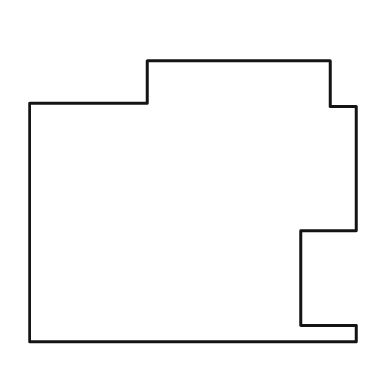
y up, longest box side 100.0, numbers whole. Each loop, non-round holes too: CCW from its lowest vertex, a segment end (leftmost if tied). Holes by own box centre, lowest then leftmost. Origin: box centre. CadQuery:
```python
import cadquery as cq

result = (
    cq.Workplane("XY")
    .moveTo(-50.0, -43.0)
    .lineTo(50.0, -43.0)
    .lineTo(50.0, -38.0)
    .lineTo(33.0, -38.0)
    .lineTo(33.0, -9.0)
    .lineTo(50.0, -9.0)
    .lineTo(50.0, 29.0)
    .lineTo(42.0, 29.0)
    .lineTo(42.0, 43.0)
    .lineTo(-14.0, 43.0)
    .lineTo(-14.0, 30.0)
    .lineTo(-50.0, 30.0)
    .close()
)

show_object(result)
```